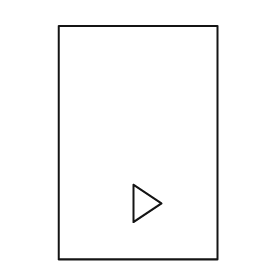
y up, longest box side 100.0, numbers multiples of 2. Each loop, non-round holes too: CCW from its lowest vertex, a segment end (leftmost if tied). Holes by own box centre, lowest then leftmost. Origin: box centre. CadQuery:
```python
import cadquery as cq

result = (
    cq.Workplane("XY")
    .moveTo(-34.0, -50.0)
    .lineTo(34.0, -50.0)
    .lineTo(34.0, 50.0)
    .lineTo(-34.0, 50.0)
    .close()
    .moveTo(-2.0, -34.0)
    .lineTo(10.0, -26.0)
    .lineTo(-2.0, -18.0)
    .close()
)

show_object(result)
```